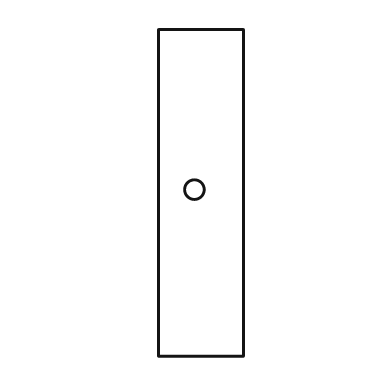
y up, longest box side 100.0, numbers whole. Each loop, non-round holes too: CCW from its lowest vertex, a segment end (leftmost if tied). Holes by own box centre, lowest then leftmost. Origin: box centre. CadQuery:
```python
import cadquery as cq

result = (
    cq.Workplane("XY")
    .moveTo(-13.0, -50.0)
    .lineTo(13.0, -50.0)
    .lineTo(13.0, 50.0)
    .lineTo(-13.0, 50.0)
    .close()
    .moveTo(-2.0, 1.0)
    .circle(3.0)
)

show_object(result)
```